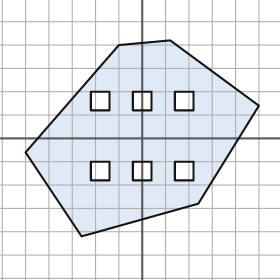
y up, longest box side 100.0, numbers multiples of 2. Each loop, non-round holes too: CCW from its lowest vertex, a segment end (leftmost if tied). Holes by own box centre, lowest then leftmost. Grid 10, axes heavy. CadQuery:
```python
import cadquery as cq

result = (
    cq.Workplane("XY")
    .moveTo(-26.0, -42.0)
    .lineTo(24.0, -28.0)
    .lineTo(50.0, 14.0)
    .lineTo(12.0, 42.0)
    .lineTo(-10.0, 40.0)
    .lineTo(-50.0, -6.0)
    .close()
    .moveTo(-22.0, -18.0)
    .lineTo(-14.0, -18.0)
    .lineTo(-14.0, -10.0)
    .lineTo(-22.0, -10.0)
    .close()
    .moveTo(-4.0, -18.0)
    .lineTo(4.0, -18.0)
    .lineTo(4.0, -10.0)
    .lineTo(-4.0, -10.0)
    .close()
    .moveTo(14.0, -18.0)
    .lineTo(22.0, -18.0)
    .lineTo(22.0, -10.0)
    .lineTo(14.0, -10.0)
    .close()
    .moveTo(-22.0, 12.0)
    .lineTo(-14.0, 12.0)
    .lineTo(-14.0, 20.0)
    .lineTo(-22.0, 20.0)
    .close()
    .moveTo(-4.0, 12.0)
    .lineTo(4.0, 12.0)
    .lineTo(4.0, 20.0)
    .lineTo(-4.0, 20.0)
    .close()
    .moveTo(14.0, 12.0)
    .lineTo(22.0, 12.0)
    .lineTo(22.0, 20.0)
    .lineTo(14.0, 20.0)
    .close()
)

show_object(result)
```